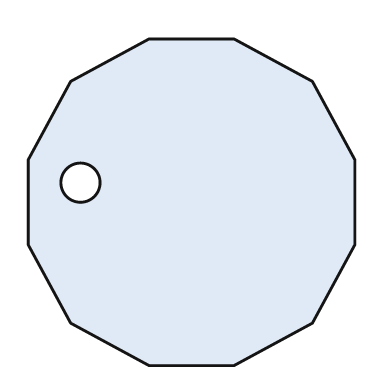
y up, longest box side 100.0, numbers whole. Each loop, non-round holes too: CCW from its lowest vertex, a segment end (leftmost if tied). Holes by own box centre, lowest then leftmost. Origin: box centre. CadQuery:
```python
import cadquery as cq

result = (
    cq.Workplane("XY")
    .moveTo(-13.0, -50.0)
    .lineTo(13.0, -50.0)
    .lineTo(37.0, -37.0)
    .lineTo(50.0, -13.0)
    .lineTo(50.0, 13.0)
    .lineTo(37.0, 37.0)
    .lineTo(13.0, 50.0)
    .lineTo(-13.0, 50.0)
    .lineTo(-37.0, 37.0)
    .lineTo(-50.0, 13.0)
    .lineTo(-50.0, -13.0)
    .lineTo(-37.0, -37.0)
    .close()
    .moveTo(-34.0, 6.0)
    .circle(6.0)
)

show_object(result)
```